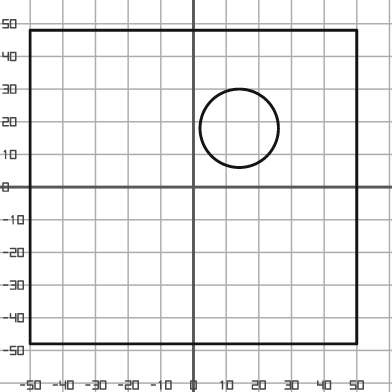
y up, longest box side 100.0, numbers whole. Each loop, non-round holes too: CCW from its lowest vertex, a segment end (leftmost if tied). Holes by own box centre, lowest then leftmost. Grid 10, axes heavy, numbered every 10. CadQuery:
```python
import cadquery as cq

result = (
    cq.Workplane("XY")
    .moveTo(-50.0, -48.0)
    .lineTo(50.0, -48.0)
    .lineTo(50.0, 48.0)
    .lineTo(-50.0, 48.0)
    .close()
    .moveTo(14.0, 18.0)
    .circle(12.0)
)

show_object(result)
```